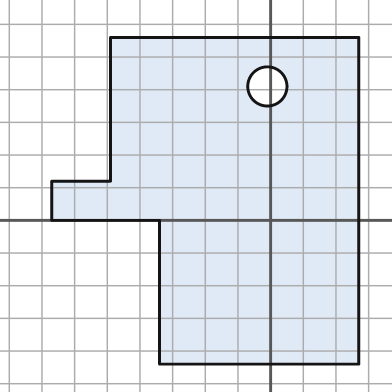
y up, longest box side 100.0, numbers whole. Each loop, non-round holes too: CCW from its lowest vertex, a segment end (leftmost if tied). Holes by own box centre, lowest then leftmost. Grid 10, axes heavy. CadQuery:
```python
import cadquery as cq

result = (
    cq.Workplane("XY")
    .moveTo(-34.0, -44.0)
    .lineTo(27.0, -44.0)
    .lineTo(27.0, 56.0)
    .lineTo(-49.0, 56.0)
    .lineTo(-49.0, 12.0)
    .lineTo(-67.0, 12.0)
    .lineTo(-67.0, 0.0)
    .lineTo(-34.0, 0.0)
    .close()
    .moveTo(-1.0, 41.0)
    .circle(6.0)
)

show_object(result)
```